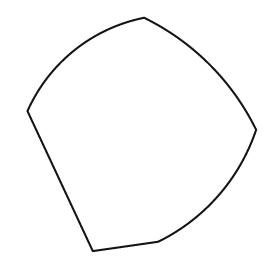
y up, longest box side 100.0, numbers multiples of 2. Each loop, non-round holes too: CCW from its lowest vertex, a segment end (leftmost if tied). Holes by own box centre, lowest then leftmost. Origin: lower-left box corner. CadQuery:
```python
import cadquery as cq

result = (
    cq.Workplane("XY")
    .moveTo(28.0, 0.0)
    .lineTo(56.0, 4.0)
    .threePointArc((82.0, 24.0), (98.0, 52.0))
    .threePointArc((78.0, 80.0), (50.0, 100.0))
    .threePointArc((20.0, 86.0), (0.0, 60.0))
    .close()
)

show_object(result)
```